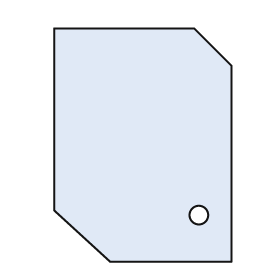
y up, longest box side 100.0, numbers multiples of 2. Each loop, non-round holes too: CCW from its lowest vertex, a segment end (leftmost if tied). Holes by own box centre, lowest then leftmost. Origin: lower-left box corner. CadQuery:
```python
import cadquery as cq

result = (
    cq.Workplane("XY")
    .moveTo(24.0, 0.0)
    .lineTo(76.0, 0.0)
    .lineTo(76.0, 84.0)
    .lineTo(60.0, 100.0)
    .lineTo(0.0, 100.0)
    .lineTo(0.0, 22.0)
    .close()
    .moveTo(62.0, 20.0)
    .circle(4.0)
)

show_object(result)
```